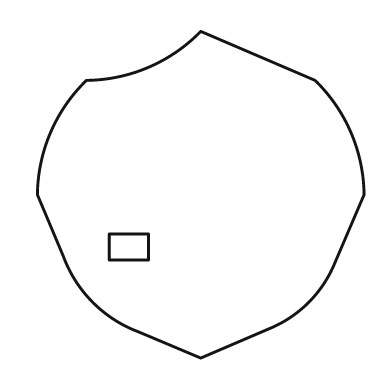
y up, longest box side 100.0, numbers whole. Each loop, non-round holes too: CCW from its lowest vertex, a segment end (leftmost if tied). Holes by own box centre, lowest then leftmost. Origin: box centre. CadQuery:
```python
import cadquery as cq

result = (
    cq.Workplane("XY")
    .moveTo(0.0, -50.0)
    .lineTo(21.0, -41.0)
    .threePointArc((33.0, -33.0), (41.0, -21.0))
    .lineTo(50.0, 0.0)
    .threePointArc((46.0, 19.0), (35.0, 35.0))
    .lineTo(0.0, 50.0)
    .threePointArc((-16.0, 39.0), (-35.0, 35.0))
    .threePointArc((-46.0, 19.0), (-50.0, 0.0))
    .lineTo(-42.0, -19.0)
    .threePointArc((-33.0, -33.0), (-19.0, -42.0))
    .close()
    .moveTo(-28.0, -20.0)
    .lineTo(-16.0, -20.0)
    .lineTo(-16.0, -12.0)
    .lineTo(-28.0, -12.0)
    .close()
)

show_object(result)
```